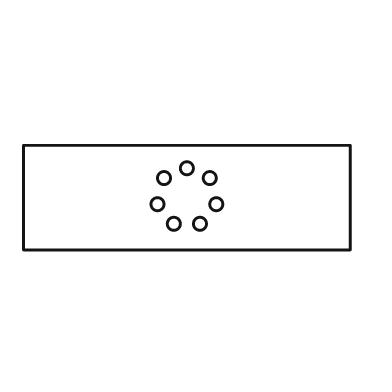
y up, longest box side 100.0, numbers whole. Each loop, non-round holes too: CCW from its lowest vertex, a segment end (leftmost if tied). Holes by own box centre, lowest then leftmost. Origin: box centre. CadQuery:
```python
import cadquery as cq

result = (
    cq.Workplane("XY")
    .moveTo(-50.0, -16.0)
    .lineTo(50.0, -16.0)
    .lineTo(50.0, 16.0)
    .lineTo(-50.0, 16.0)
    .close()
    .moveTo(-4.0, -8.0)
    .circle(2.0)
    .moveTo(4.0, -8.0)
    .circle(2.0)
    .moveTo(-9.0, -2.0)
    .circle(2.0)
    .moveTo(9.0, -2.0)
    .circle(2.0)
    .moveTo(-7.0, 6.0)
    .circle(2.0)
    .moveTo(7.0, 6.0)
    .circle(2.0)
    .moveTo(0.0, 9.0)
    .circle(2.0)
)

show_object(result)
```